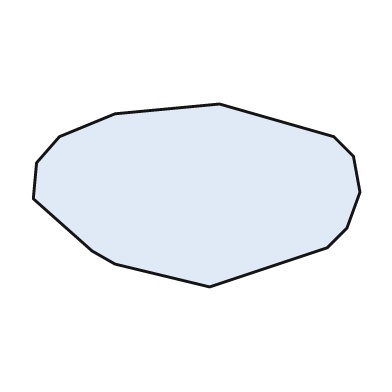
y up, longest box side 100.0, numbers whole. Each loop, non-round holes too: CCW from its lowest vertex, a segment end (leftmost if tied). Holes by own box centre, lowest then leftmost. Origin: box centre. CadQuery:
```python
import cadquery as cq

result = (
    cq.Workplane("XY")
    .moveTo(4.0, -28.0)
    .lineTo(40.0, -16.0)
    .lineTo(46.0, -10.0)
    .lineTo(50.0, 1.0)
    .lineTo(48.0, 12.0)
    .lineTo(42.0, 18.0)
    .lineTo(7.0, 28.0)
    .lineTo(-25.0, 25.0)
    .lineTo(-42.0, 18.0)
    .lineTo(-49.0, 10.0)
    .lineTo(-50.0, -1.0)
    .lineTo(-32.0, -17.0)
    .lineTo(-25.0, -21.0)
    .close()
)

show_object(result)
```